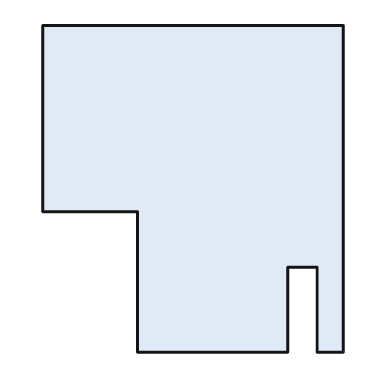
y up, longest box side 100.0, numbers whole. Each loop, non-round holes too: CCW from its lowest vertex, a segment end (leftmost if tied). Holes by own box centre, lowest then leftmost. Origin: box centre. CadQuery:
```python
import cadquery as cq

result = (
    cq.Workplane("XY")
    .moveTo(-17.0, -50.0)
    .lineTo(29.0, -50.0)
    .lineTo(29.0, -24.0)
    .lineTo(38.0, -24.0)
    .lineTo(38.0, -50.0)
    .lineTo(46.0, -50.0)
    .lineTo(46.0, 50.0)
    .lineTo(-46.0, 50.0)
    .lineTo(-46.0, -7.0)
    .lineTo(-17.0, -7.0)
    .close()
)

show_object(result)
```